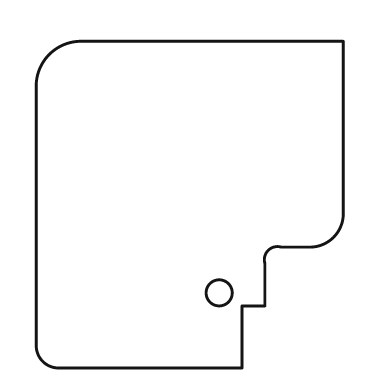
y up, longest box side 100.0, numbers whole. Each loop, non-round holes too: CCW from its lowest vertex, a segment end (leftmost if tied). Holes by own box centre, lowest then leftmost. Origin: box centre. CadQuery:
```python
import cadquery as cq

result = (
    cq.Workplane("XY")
    .moveTo(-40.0, -50.0)
    .lineTo(16.0, -50.0)
    .lineTo(16.0, -31.0)
    .lineTo(23.0, -31.0)
    .lineTo(23.0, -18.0)
    .threePointArc((24.0, -14.0), (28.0, -13.0))
    .lineTo(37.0, -13.0)
    .threePointArc((44.0, -10.0), (47.0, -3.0))
    .lineTo(47.0, 50.0)
    .lineTo(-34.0, 50.0)
    .threePointArc((-43.0, 46.0), (-47.0, 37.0))
    .lineTo(-47.0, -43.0)
    .threePointArc((-45.0, -48.0), (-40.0, -50.0))
    .close()
    .moveTo(9.0, -27.0)
    .circle(4.0)
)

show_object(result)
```